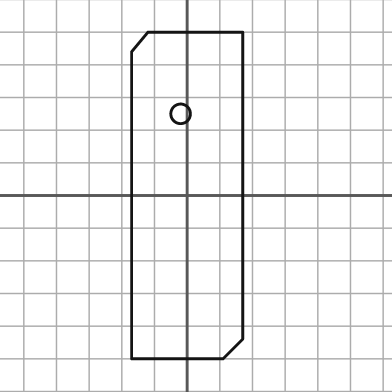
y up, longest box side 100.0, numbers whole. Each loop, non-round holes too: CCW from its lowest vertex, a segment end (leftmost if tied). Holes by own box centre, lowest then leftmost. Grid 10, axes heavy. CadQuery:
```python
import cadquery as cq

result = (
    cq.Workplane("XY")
    .moveTo(-17.0, -50.0)
    .lineTo(11.0, -50.0)
    .lineTo(17.0, -44.0)
    .lineTo(17.0, 50.0)
    .lineTo(-12.0, 50.0)
    .lineTo(-17.0, 44.0)
    .close()
    .moveTo(-2.0, 25.0)
    .circle(3.0)
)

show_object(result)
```